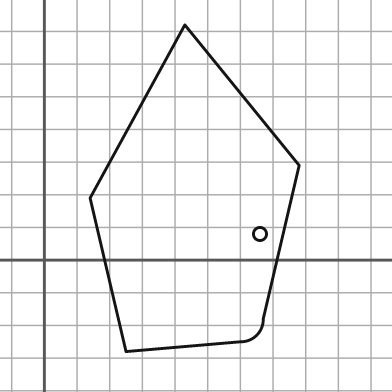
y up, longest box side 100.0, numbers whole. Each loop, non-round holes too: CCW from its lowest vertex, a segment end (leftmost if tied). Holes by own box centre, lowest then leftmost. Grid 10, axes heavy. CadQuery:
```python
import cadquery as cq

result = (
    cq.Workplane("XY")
    .moveTo(25.0, -28.0)
    .lineTo(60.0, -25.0)
    .threePointArc((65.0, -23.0), (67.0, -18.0))
    .lineTo(78.0, 29.0)
    .lineTo(43.0, 72.0)
    .lineTo(14.0, 19.0)
    .close()
    .moveTo(66.0, 8.0)
    .circle(2.0)
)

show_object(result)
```